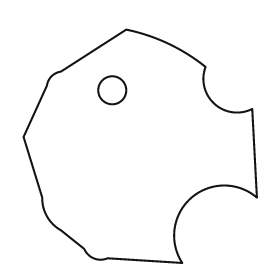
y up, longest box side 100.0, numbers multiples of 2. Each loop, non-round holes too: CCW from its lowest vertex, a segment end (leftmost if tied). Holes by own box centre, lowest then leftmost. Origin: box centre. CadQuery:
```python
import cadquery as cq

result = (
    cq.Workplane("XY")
    .moveTo(18.0, -50.0)
    .threePointArc((22.0, -22.0), (50.0, -22.0))
    .lineTo(48.0, 16.0)
    .threePointArc((32.0, 18.0), (28.0, 34.0))
    .threePointArc((12.0, 44.0), (-6.0, 50.0))
    .lineTo(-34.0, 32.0)
    .threePointArc((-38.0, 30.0), (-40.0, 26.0))
    .lineTo(-50.0, 4.0)
    .lineTo(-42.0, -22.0)
    .threePointArc((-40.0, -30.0), (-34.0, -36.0))
    .lineTo(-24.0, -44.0)
    .threePointArc((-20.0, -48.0), (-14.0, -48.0))
    .close()
    .moveTo(-12.0, 24.0)
    .circle(6.0)
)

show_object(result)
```